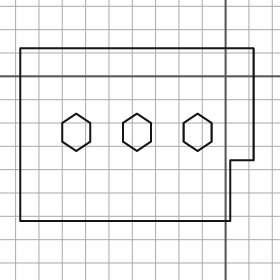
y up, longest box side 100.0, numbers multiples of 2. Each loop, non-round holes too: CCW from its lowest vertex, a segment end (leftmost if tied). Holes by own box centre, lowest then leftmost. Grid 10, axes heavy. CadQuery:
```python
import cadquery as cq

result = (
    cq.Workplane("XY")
    .moveTo(-88.0, -62.0)
    .lineTo(2.0, -62.0)
    .lineTo(2.0, -36.0)
    .lineTo(12.0, -36.0)
    .lineTo(12.0, 12.0)
    .lineTo(-88.0, 12.0)
    .close()
    .moveTo(-64.0, -32.0)
    .lineTo(-58.0, -28.0)
    .lineTo(-58.0, -20.0)
    .lineTo(-64.0, -16.0)
    .lineTo(-70.0, -20.0)
    .lineTo(-70.0, -28.0)
    .close()
    .moveTo(-38.0, -32.0)
    .lineTo(-32.0, -28.0)
    .lineTo(-32.0, -20.0)
    .lineTo(-38.0, -16.0)
    .lineTo(-44.0, -20.0)
    .lineTo(-44.0, -28.0)
    .close()
    .moveTo(-12.0, -32.0)
    .lineTo(-6.0, -28.0)
    .lineTo(-6.0, -20.0)
    .lineTo(-12.0, -16.0)
    .lineTo(-18.0, -20.0)
    .lineTo(-18.0, -28.0)
    .close()
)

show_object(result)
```